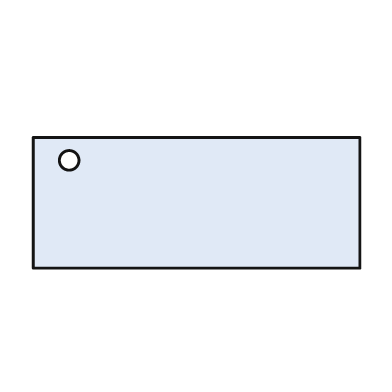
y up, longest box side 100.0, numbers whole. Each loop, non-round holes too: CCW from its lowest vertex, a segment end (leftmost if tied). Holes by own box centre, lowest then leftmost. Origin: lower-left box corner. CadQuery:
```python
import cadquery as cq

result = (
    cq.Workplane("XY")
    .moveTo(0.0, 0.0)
    .lineTo(100.0, 0.0)
    .lineTo(100.0, 40.0)
    .lineTo(0.0, 40.0)
    .close()
    .moveTo(11.0, 33.0)
    .circle(3.0)
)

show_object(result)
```